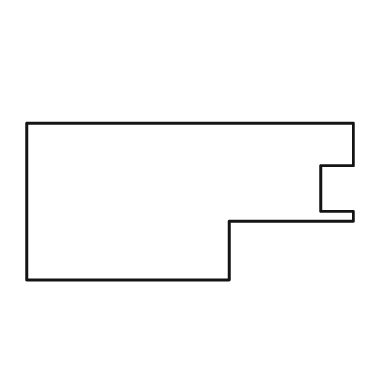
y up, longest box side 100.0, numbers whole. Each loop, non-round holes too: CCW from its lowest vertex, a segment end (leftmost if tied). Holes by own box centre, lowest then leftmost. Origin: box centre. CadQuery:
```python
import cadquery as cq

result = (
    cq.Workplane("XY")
    .moveTo(-50.0, -24.0)
    .lineTo(12.0, -24.0)
    .lineTo(12.0, -6.0)
    .lineTo(50.0, -6.0)
    .lineTo(50.0, -3.0)
    .lineTo(40.0, -3.0)
    .lineTo(40.0, 11.0)
    .lineTo(50.0, 11.0)
    .lineTo(50.0, 24.0)
    .lineTo(-50.0, 24.0)
    .close()
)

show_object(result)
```